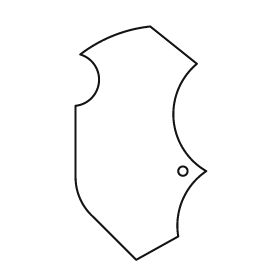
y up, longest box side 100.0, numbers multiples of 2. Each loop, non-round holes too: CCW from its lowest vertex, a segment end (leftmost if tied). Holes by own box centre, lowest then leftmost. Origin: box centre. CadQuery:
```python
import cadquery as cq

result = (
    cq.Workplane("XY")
    .moveTo(-2.0, -50.0)
    .lineTo(16.0, -40.0)
    .threePointArc((18.0, -24.0), (28.0, -12.0))
    .threePointArc((14.0, 10.0), (24.0, 34.0))
    .lineTo(4.0, 50.0)
    .threePointArc((-12.0, 46.0), (-26.0, 38.0))
    .threePointArc((-18.0, 26.0), (-28.0, 16.0))
    .lineTo(-28.0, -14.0)
    .threePointArc((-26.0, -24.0), (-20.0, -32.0))
    .close()
    .moveTo(18.0, -12.0)
    .circle(2.0)
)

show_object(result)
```